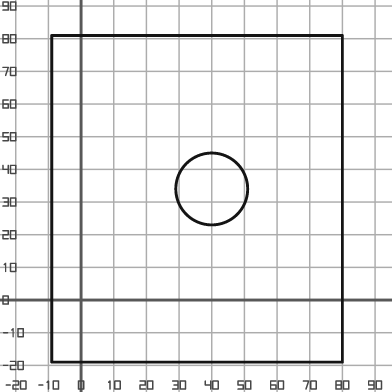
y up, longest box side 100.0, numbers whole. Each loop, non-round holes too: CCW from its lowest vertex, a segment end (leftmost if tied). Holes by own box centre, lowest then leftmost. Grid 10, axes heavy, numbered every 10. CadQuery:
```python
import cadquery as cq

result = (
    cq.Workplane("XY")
    .moveTo(-9.0, -19.0)
    .lineTo(80.0, -19.0)
    .lineTo(80.0, 81.0)
    .lineTo(-9.0, 81.0)
    .close()
    .moveTo(40.0, 34.0)
    .circle(11.0)
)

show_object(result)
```